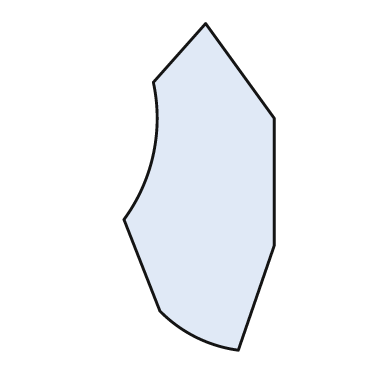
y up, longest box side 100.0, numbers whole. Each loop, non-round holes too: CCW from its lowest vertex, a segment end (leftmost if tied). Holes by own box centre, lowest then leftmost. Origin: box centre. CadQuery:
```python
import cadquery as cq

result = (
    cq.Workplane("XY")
    .moveTo(12.0, -50.0)
    .lineTo(23.0, -18.0)
    .lineTo(23.0, 21.0)
    .lineTo(2.0, 50.0)
    .lineTo(-14.0, 32.0)
    .threePointArc((-14.0, 10.0), (-23.0, -10.0))
    .lineTo(-12.0, -38.0)
    .threePointArc((-1.0, -46.0), (12.0, -50.0))
    .close()
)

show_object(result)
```